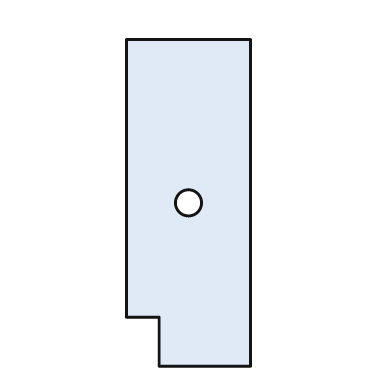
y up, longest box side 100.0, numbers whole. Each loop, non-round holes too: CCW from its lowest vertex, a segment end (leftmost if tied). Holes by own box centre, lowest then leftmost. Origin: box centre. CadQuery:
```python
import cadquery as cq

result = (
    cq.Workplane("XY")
    .moveTo(-9.0, -50.0)
    .lineTo(19.0, -50.0)
    .lineTo(19.0, 50.0)
    .lineTo(-19.0, 50.0)
    .lineTo(-19.0, -35.0)
    .lineTo(-9.0, -35.0)
    .close()
    .moveTo(0.0, 0.0)
    .circle(4.0)
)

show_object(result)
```